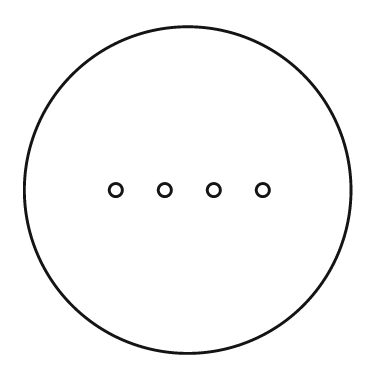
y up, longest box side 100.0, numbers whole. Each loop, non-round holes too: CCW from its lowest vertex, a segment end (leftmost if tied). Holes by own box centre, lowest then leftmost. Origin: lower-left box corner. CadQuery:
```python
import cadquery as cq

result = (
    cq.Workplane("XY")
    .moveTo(50.0, 50.0)
    .circle(50.0)
    .moveTo(28.0, 50.0)
    .circle(2.0)
    .moveTo(43.0, 50.0)
    .circle(2.0)
    .moveTo(58.0, 50.0)
    .circle(2.0)
    .moveTo(73.0, 50.0)
    .circle(2.0)
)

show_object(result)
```